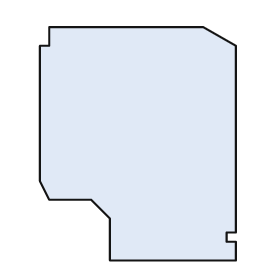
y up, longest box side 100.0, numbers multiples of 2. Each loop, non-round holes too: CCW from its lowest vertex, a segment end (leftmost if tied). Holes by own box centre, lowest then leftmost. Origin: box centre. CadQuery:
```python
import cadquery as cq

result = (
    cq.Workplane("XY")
    .moveTo(-12.0, -50.0)
    .lineTo(42.0, -50.0)
    .lineTo(42.0, -42.0)
    .lineTo(38.0, -42.0)
    .lineTo(38.0, -38.0)
    .lineTo(42.0, -38.0)
    .lineTo(42.0, 42.0)
    .lineTo(28.0, 50.0)
    .lineTo(-38.0, 50.0)
    .lineTo(-38.0, 42.0)
    .lineTo(-42.0, 42.0)
    .lineTo(-42.0, -16.0)
    .lineTo(-38.0, -24.0)
    .lineTo(-20.0, -24.0)
    .lineTo(-12.0, -32.0)
    .close()
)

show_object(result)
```